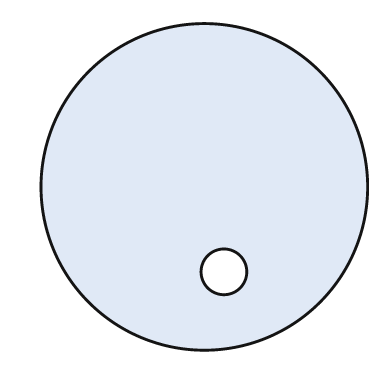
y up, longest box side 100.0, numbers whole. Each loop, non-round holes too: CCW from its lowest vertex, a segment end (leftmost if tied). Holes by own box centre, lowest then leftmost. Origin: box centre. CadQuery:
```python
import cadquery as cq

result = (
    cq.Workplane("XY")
    .moveTo(0.0, 0.0)
    .circle(50.0)
    .moveTo(6.0, -26.0)
    .circle(7.0)
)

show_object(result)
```